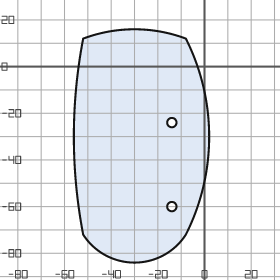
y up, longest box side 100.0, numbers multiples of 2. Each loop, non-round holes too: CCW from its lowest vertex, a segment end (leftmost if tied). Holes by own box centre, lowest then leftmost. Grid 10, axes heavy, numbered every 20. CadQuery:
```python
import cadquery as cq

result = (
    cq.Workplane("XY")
    .moveTo(-52.0, -72.0)
    .threePointArc((-30.0, -84.0), (-8.0, -72.0))
    .threePointArc((2.0, -30.0), (-8.0, 12.0))
    .threePointArc((-30.0, 16.0), (-52.0, 12.0))
    .threePointArc((-56.0, -30.0), (-52.0, -72.0))
    .close()
    .moveTo(-14.0, -60.0)
    .circle(2.0)
    .moveTo(-14.0, -24.0)
    .circle(2.0)
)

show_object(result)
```